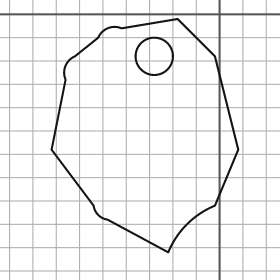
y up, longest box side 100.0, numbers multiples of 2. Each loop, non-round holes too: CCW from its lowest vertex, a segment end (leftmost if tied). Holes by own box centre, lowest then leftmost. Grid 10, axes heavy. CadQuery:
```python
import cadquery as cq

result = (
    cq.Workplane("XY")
    .moveTo(-22.0, -102.0)
    .threePointArc((-14.0, -90.0), (-2.0, -82.0))
    .lineTo(8.0, -58.0)
    .lineTo(-2.0, -18.0)
    .lineTo(-18.0, -2.0)
    .lineTo(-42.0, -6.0)
    .threePointArc((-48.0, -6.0), (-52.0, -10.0))
    .lineTo(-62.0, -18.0)
    .threePointArc((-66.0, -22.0), (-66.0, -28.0))
    .lineTo(-72.0, -58.0)
    .lineTo(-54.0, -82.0)
    .threePointArc((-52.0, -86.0), (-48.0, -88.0))
    .close()
    .moveTo(-28.0, -18.0)
    .circle(8.0)
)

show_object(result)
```